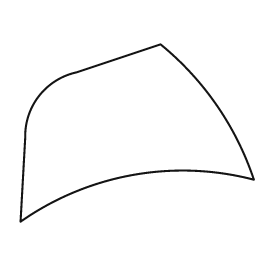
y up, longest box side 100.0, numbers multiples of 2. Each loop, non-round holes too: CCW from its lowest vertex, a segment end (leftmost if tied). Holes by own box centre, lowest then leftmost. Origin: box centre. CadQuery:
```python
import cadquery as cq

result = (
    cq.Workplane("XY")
    .moveTo(-50.0, -38.0)
    .threePointArc((-2.0, -18.0), (50.0, -20.0))
    .threePointArc((34.0, 12.0), (10.0, 38.0))
    .lineTo(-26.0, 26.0)
    .threePointArc((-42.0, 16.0), (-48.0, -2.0))
    .close()
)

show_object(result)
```